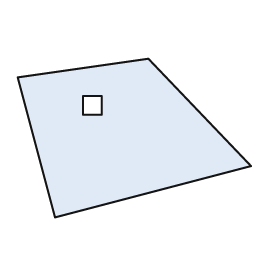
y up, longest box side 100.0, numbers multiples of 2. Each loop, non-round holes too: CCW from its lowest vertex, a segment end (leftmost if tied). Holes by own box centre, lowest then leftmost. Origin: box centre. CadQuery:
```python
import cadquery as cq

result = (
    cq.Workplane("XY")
    .moveTo(-34.0, -34.0)
    .lineTo(50.0, -12.0)
    .lineTo(6.0, 34.0)
    .lineTo(-50.0, 26.0)
    .close()
    .moveTo(-22.0, 10.0)
    .lineTo(-14.0, 10.0)
    .lineTo(-14.0, 18.0)
    .lineTo(-22.0, 18.0)
    .close()
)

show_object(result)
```